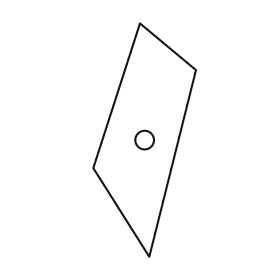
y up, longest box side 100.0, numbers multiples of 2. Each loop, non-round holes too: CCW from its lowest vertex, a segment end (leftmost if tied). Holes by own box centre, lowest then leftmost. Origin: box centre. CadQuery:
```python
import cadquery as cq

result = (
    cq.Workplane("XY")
    .moveTo(2.0, -50.0)
    .lineTo(22.0, 30.0)
    .lineTo(-2.0, 50.0)
    .lineTo(-22.0, -12.0)
    .close()
    .moveTo(0.0, 0.0)
    .circle(4.0)
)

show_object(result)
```